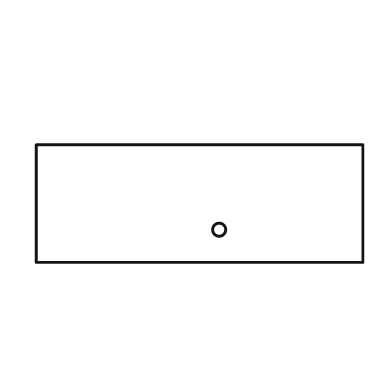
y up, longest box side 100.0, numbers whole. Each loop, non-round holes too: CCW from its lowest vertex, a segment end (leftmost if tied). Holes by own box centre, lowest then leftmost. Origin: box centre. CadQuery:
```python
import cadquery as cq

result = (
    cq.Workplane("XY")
    .moveTo(-50.0, -18.0)
    .lineTo(50.0, -18.0)
    .lineTo(50.0, 18.0)
    .lineTo(-50.0, 18.0)
    .close()
    .moveTo(6.0, -8.0)
    .circle(2.0)
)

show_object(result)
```